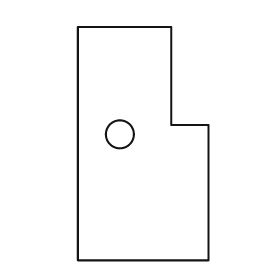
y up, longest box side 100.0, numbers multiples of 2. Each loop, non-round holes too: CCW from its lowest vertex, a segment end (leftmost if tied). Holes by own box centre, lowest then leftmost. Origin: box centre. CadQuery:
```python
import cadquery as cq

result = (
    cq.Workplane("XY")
    .moveTo(-28.0, -50.0)
    .lineTo(28.0, -50.0)
    .lineTo(28.0, 8.0)
    .lineTo(12.0, 8.0)
    .lineTo(12.0, 50.0)
    .lineTo(-28.0, 50.0)
    .close()
    .moveTo(-10.0, 4.0)
    .circle(6.0)
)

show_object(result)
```